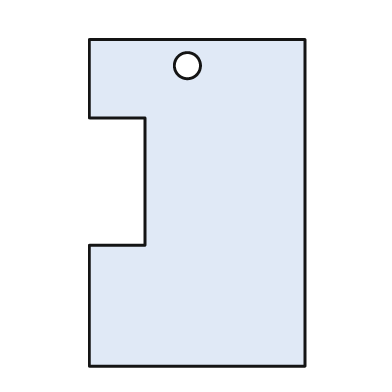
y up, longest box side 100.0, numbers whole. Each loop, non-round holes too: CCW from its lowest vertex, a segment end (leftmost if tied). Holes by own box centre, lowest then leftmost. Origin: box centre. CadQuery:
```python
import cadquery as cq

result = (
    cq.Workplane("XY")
    .moveTo(-33.0, -50.0)
    .lineTo(33.0, -50.0)
    .lineTo(33.0, 50.0)
    .lineTo(-33.0, 50.0)
    .lineTo(-33.0, 26.0)
    .lineTo(-16.0, 26.0)
    .lineTo(-16.0, -13.0)
    .lineTo(-33.0, -13.0)
    .close()
    .moveTo(-3.0, 42.0)
    .circle(4.0)
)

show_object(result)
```